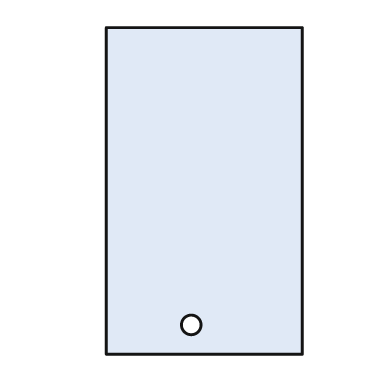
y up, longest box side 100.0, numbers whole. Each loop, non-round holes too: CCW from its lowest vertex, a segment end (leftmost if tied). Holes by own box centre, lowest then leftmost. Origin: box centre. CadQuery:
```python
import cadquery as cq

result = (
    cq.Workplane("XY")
    .moveTo(-30.0, -50.0)
    .lineTo(30.0, -50.0)
    .lineTo(30.0, 50.0)
    .lineTo(-30.0, 50.0)
    .close()
    .moveTo(-4.0, -41.0)
    .circle(3.0)
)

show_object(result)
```